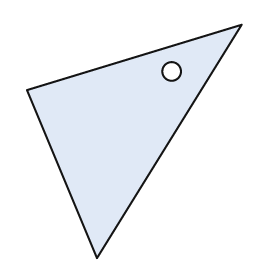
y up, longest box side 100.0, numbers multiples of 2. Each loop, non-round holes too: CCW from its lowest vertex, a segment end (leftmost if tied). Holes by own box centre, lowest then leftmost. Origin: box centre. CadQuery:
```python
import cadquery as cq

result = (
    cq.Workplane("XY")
    .moveTo(-16.0, -50.0)
    .lineTo(46.0, 50.0)
    .lineTo(-46.0, 22.0)
    .close()
    .moveTo(16.0, 30.0)
    .circle(4.0)
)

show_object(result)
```